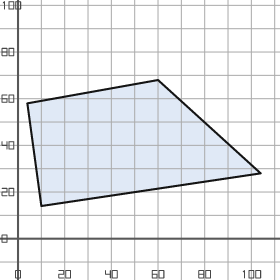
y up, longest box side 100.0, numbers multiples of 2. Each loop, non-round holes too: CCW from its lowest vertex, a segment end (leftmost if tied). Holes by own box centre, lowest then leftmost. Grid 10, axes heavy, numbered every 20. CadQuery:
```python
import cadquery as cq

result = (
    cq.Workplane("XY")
    .moveTo(10.0, 14.0)
    .lineTo(104.0, 28.0)
    .lineTo(60.0, 68.0)
    .lineTo(4.0, 58.0)
    .close()
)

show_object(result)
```